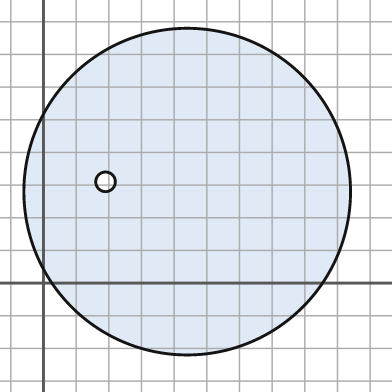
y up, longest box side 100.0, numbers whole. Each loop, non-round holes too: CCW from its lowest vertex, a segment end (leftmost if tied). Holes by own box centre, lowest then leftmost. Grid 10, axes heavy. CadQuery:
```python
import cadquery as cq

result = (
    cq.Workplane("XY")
    .moveTo(44.0, 28.0)
    .circle(50.0)
    .moveTo(19.0, 31.0)
    .circle(3.0)
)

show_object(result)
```